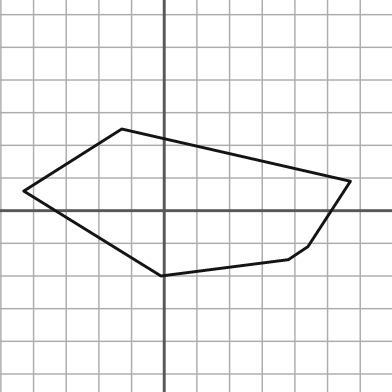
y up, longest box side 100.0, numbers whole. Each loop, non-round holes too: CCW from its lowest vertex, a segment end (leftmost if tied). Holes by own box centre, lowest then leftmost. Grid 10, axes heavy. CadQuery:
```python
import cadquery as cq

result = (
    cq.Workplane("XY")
    .moveTo(-1.0, -20.0)
    .lineTo(38.0, -15.0)
    .lineTo(44.0, -11.0)
    .lineTo(57.0, 9.0)
    .lineTo(-13.0, 25.0)
    .lineTo(-43.0, 6.0)
    .close()
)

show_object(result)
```